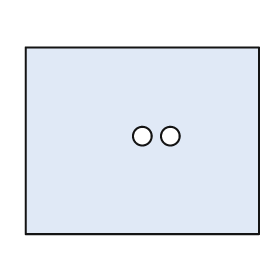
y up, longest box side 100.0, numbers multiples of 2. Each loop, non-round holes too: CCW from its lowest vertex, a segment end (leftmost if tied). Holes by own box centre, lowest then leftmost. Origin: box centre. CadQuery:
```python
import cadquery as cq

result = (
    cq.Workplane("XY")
    .moveTo(-50.0, -40.0)
    .lineTo(50.0, -40.0)
    .lineTo(50.0, 40.0)
    .lineTo(-50.0, 40.0)
    .close()
    .moveTo(0.0, 2.0)
    .circle(4.0)
    .moveTo(12.0, 2.0)
    .circle(4.0)
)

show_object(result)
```